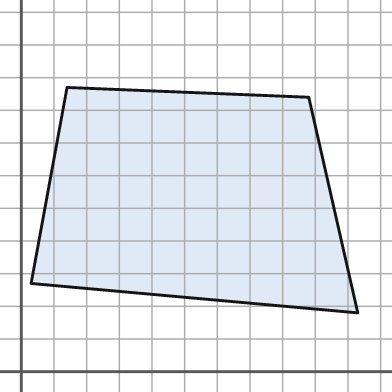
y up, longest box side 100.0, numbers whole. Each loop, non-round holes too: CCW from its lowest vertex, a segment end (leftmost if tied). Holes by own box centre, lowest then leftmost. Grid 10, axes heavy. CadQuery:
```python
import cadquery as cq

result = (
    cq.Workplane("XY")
    .moveTo(103.0, 18.0)
    .lineTo(88.0, 84.0)
    .lineTo(14.0, 87.0)
    .lineTo(3.0, 27.0)
    .close()
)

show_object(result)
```